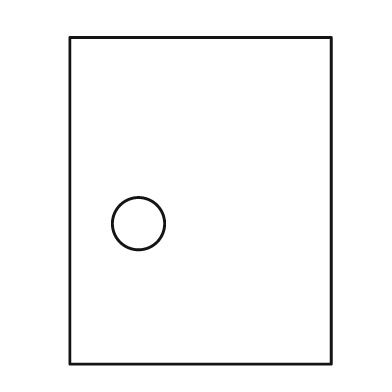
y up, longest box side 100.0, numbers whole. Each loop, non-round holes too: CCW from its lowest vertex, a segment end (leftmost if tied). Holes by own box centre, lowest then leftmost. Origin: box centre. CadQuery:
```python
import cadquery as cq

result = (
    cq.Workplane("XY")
    .moveTo(-40.0, -50.0)
    .lineTo(40.0, -50.0)
    .lineTo(40.0, 50.0)
    .lineTo(-40.0, 50.0)
    .close()
    .moveTo(-19.0, -7.0)
    .circle(8.0)
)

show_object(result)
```